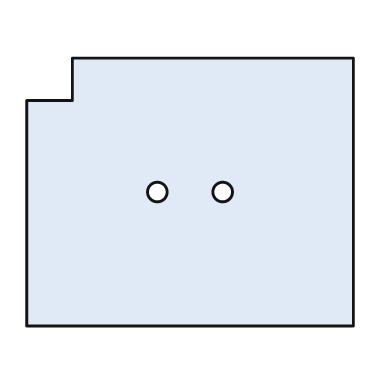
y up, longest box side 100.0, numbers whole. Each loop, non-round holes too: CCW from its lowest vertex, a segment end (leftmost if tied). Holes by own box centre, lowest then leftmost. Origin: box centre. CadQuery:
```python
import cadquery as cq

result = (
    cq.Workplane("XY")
    .moveTo(-50.0, -41.0)
    .lineTo(50.0, -41.0)
    .lineTo(50.0, 41.0)
    .lineTo(-36.0, 41.0)
    .lineTo(-36.0, 28.0)
    .lineTo(-50.0, 28.0)
    .close()
    .moveTo(-10.0, 0.0)
    .circle(3.0)
    .moveTo(10.0, 0.0)
    .circle(3.0)
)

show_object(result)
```